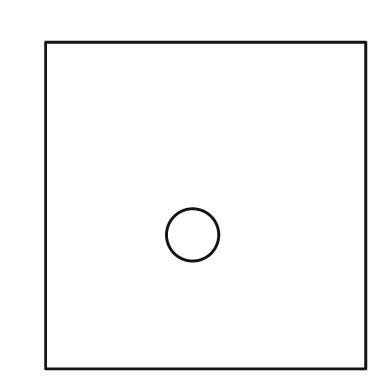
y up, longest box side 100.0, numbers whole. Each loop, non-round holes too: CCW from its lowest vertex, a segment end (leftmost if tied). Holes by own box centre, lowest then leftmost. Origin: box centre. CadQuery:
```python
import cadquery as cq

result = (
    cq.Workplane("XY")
    .moveTo(-49.0, -50.0)
    .lineTo(49.0, -50.0)
    .lineTo(49.0, 50.0)
    .lineTo(-49.0, 50.0)
    .close()
    .moveTo(-4.0, -9.0)
    .circle(8.0)
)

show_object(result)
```